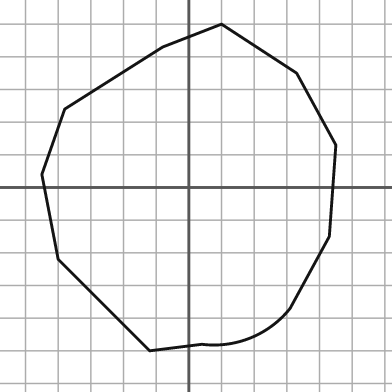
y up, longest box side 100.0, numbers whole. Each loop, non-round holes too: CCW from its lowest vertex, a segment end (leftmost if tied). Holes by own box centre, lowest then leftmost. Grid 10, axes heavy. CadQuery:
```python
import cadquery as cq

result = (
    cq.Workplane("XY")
    .moveTo(-12.0, -50.0)
    .lineTo(4.0, -48.0)
    .threePointArc((19.0, -46.0), (31.0, -37.0))
    .lineTo(43.0, -15.0)
    .lineTo(45.0, 13.0)
    .lineTo(33.0, 35.0)
    .lineTo(10.0, 50.0)
    .lineTo(-8.0, 43.0)
    .lineTo(-38.0, 24.0)
    .lineTo(-45.0, 4.0)
    .lineTo(-40.0, -22.0)
    .close()
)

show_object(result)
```